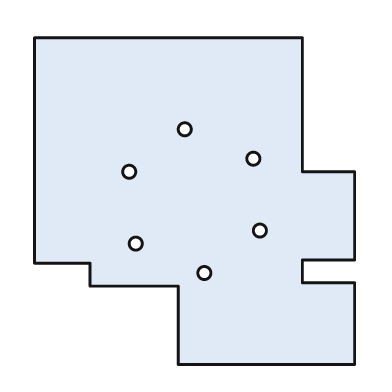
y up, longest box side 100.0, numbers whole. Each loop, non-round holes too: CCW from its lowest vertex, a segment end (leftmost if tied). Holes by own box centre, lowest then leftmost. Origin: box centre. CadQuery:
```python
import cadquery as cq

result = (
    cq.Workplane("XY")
    .moveTo(-5.0, -50.0)
    .lineTo(49.0, -50.0)
    .lineTo(49.0, -25.0)
    .lineTo(33.0, -25.0)
    .lineTo(33.0, -18.0)
    .lineTo(49.0, -18.0)
    .lineTo(49.0, 9.0)
    .lineTo(33.0, 9.0)
    .lineTo(33.0, 50.0)
    .lineTo(-49.0, 50.0)
    .lineTo(-49.0, -19.0)
    .lineTo(-32.0, -19.0)
    .lineTo(-32.0, -26.0)
    .lineTo(-5.0, -26.0)
    .close()
    .moveTo(3.0, -22.0)
    .circle(2.0)
    .moveTo(-18.0, -13.0)
    .circle(2.0)
    .moveTo(20.0, -9.0)
    .circle(2.0)
    .moveTo(-20.0, 9.0)
    .circle(2.0)
    .moveTo(18.0, 13.0)
    .circle(2.0)
    .moveTo(-3.0, 22.0)
    .circle(2.0)
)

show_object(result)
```